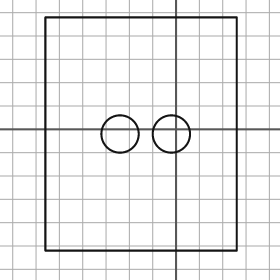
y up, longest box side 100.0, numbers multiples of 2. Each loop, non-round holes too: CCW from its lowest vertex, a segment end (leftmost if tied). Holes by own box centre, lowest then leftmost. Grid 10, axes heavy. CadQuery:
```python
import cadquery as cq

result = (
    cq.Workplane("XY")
    .moveTo(-56.0, -52.0)
    .lineTo(26.0, -52.0)
    .lineTo(26.0, 48.0)
    .lineTo(-56.0, 48.0)
    .close()
    .moveTo(-24.0, -2.0)
    .circle(8.0)
    .moveTo(-2.0, -2.0)
    .circle(8.0)
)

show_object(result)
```